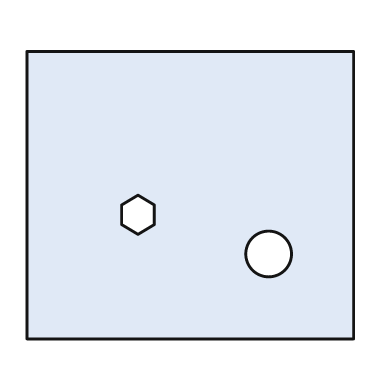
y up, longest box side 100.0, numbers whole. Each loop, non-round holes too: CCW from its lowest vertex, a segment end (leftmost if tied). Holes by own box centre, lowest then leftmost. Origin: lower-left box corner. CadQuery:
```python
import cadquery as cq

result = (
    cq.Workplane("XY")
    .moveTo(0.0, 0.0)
    .lineTo(100.0, 0.0)
    .lineTo(100.0, 88.0)
    .lineTo(0.0, 88.0)
    .close()
    .moveTo(74.0, 26.0)
    .circle(7.0)
    .moveTo(34.0, 32.0)
    .lineTo(39.0, 35.0)
    .lineTo(39.0, 41.0)
    .lineTo(34.0, 44.0)
    .lineTo(29.0, 41.0)
    .lineTo(29.0, 35.0)
    .close()
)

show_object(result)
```